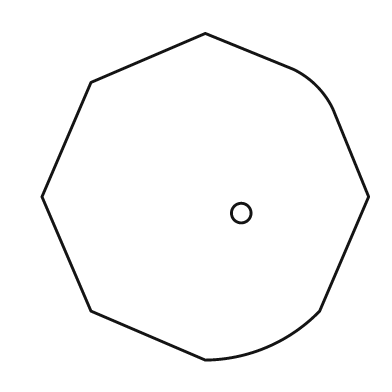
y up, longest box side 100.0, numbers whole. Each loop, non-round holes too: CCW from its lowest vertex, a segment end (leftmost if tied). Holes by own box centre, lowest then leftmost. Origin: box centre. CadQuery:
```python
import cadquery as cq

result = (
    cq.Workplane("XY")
    .moveTo(0.0, -50.0)
    .threePointArc((19.0, -46.0), (35.0, -35.0))
    .lineTo(50.0, 0.0)
    .lineTo(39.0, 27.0)
    .threePointArc((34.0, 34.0), (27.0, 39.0))
    .lineTo(0.0, 50.0)
    .lineTo(-35.0, 35.0)
    .lineTo(-50.0, 0.0)
    .lineTo(-35.0, -35.0)
    .close()
    .moveTo(11.0, -5.0)
    .circle(3.0)
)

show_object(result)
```